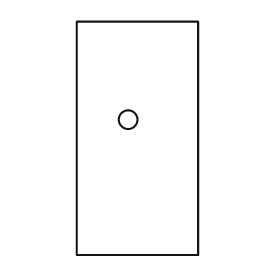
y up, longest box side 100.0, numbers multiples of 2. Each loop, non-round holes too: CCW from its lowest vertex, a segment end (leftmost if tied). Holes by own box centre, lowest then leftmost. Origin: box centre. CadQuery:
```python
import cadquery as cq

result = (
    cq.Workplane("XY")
    .moveTo(-26.0, -50.0)
    .lineTo(26.0, -50.0)
    .lineTo(26.0, 50.0)
    .lineTo(-26.0, 50.0)
    .close()
    .moveTo(-4.0, 8.0)
    .circle(4.0)
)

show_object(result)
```